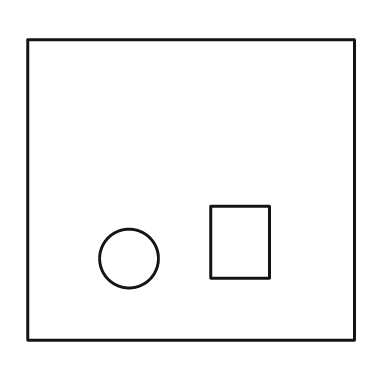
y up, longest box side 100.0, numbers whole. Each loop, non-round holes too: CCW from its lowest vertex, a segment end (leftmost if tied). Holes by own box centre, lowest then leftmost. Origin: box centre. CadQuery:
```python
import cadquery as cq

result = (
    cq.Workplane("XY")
    .moveTo(-50.0, -46.0)
    .lineTo(50.0, -46.0)
    .lineTo(50.0, 46.0)
    .lineTo(-50.0, 46.0)
    .close()
    .moveTo(-19.0, -21.0)
    .circle(9.0)
    .moveTo(6.0, -27.0)
    .lineTo(24.0, -27.0)
    .lineTo(24.0, -5.0)
    .lineTo(6.0, -5.0)
    .close()
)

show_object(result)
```